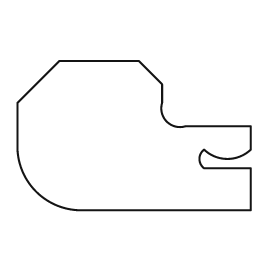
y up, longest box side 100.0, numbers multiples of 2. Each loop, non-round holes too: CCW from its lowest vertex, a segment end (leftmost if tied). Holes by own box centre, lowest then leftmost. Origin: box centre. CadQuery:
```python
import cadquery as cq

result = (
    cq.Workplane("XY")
    .moveTo(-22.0, -32.0)
    .lineTo(50.0, -32.0)
    .lineTo(50.0, -14.0)
    .lineTo(30.0, -14.0)
    .threePointArc((28.0, -10.0), (30.0, -6.0))
    .threePointArc((40.0, -10.0), (50.0, -6.0))
    .lineTo(50.0, 4.0)
    .lineTo(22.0, 4.0)
    .threePointArc((14.0, 6.0), (12.0, 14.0))
    .lineTo(12.0, 22.0)
    .lineTo(2.0, 32.0)
    .lineTo(-32.0, 32.0)
    .lineTo(-50.0, 14.0)
    .lineTo(-50.0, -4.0)
    .threePointArc((-42.0, -24.0), (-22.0, -32.0))
    .close()
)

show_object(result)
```